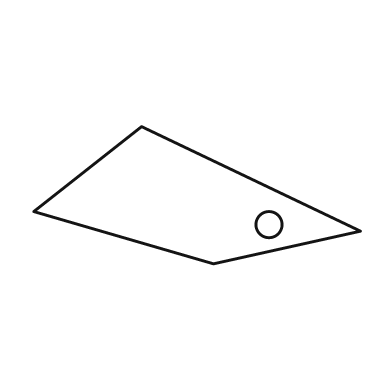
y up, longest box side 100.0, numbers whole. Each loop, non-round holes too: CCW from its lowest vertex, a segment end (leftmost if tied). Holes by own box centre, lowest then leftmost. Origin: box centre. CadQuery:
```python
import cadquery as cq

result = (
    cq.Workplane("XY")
    .moveTo(5.0, -21.0)
    .lineTo(50.0, -11.0)
    .lineTo(-17.0, 21.0)
    .lineTo(-50.0, -5.0)
    .close()
    .moveTo(22.0, -9.0)
    .circle(4.0)
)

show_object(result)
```